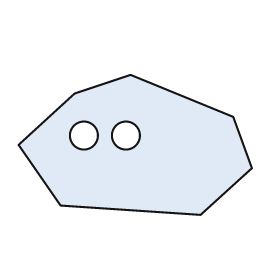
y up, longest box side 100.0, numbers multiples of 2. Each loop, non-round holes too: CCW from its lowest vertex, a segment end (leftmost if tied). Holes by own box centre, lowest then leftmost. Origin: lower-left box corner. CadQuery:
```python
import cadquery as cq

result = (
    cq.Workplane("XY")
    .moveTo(78.0, 0.0)
    .lineTo(100.0, 20.0)
    .lineTo(92.0, 42.0)
    .lineTo(48.0, 60.0)
    .lineTo(24.0, 52.0)
    .lineTo(0.0, 30.0)
    .lineTo(18.0, 4.0)
    .close()
    .moveTo(28.0, 34.0)
    .circle(6.0)
    .moveTo(46.0, 34.0)
    .circle(6.0)
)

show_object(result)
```